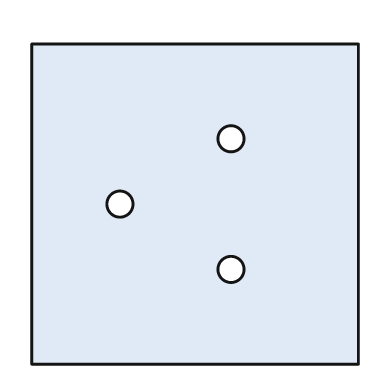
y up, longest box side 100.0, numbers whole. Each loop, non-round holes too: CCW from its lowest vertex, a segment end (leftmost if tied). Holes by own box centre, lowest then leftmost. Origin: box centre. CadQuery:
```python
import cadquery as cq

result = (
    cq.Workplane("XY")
    .moveTo(-50.0, -49.0)
    .lineTo(50.0, -49.0)
    .lineTo(50.0, 49.0)
    .lineTo(-50.0, 49.0)
    .close()
    .moveTo(11.0, -20.0)
    .circle(4.0)
    .moveTo(-23.0, 0.0)
    .circle(4.0)
    .moveTo(11.0, 20.0)
    .circle(4.0)
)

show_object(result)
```